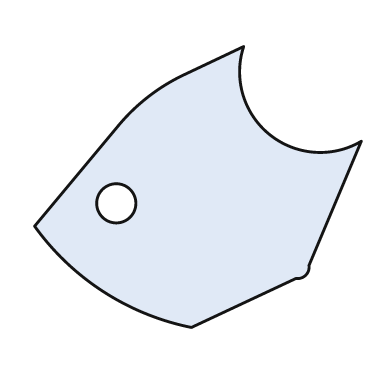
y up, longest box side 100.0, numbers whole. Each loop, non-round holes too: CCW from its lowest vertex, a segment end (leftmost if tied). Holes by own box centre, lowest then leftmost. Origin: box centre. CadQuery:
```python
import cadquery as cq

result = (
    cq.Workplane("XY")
    .moveTo(-2.0, -43.0)
    .lineTo(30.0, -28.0)
    .threePointArc((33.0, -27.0), (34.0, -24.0))
    .lineTo(50.0, 14.0)
    .threePointArc((22.0, 16.0), (14.0, 43.0))
    .lineTo(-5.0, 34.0)
    .threePointArc((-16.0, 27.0), (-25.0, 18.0))
    .lineTo(-50.0, -12.0)
    .threePointArc((-29.0, -32.0), (-2.0, -43.0))
    .close()
    .moveTo(-25.0, -5.0)
    .circle(6.0)
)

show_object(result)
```